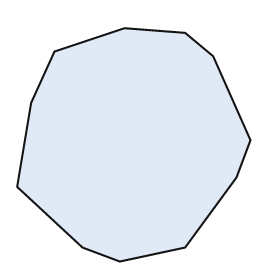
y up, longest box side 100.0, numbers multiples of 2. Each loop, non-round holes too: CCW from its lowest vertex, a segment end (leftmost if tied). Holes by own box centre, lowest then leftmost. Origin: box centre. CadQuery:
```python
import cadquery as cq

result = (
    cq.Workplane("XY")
    .moveTo(-6.0, -50.0)
    .lineTo(22.0, -44.0)
    .lineTo(44.0, -14.0)
    .lineTo(50.0, 2.0)
    .lineTo(34.0, 38.0)
    .lineTo(22.0, 48.0)
    .lineTo(-4.0, 50.0)
    .lineTo(-34.0, 40.0)
    .lineTo(-44.0, 18.0)
    .lineTo(-50.0, -18.0)
    .lineTo(-22.0, -44.0)
    .close()
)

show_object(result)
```